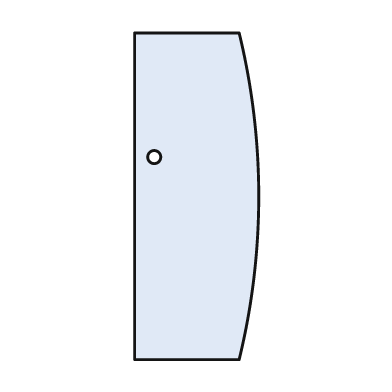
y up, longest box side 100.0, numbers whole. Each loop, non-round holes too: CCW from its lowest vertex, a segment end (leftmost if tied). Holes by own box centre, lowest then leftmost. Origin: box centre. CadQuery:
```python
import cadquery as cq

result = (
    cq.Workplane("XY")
    .moveTo(-19.0, -50.0)
    .lineTo(13.0, -50.0)
    .threePointArc((19.0, 0.0), (13.0, 50.0))
    .lineTo(-19.0, 50.0)
    .close()
    .moveTo(-13.0, 12.0)
    .circle(2.0)
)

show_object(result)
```